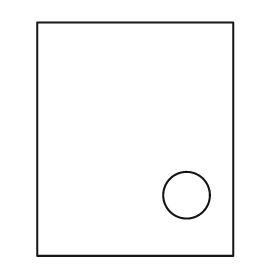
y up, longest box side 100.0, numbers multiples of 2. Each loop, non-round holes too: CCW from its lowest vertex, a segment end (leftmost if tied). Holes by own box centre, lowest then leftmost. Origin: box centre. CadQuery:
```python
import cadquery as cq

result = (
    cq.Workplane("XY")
    .moveTo(-42.0, -50.0)
    .lineTo(42.0, -50.0)
    .lineTo(42.0, 50.0)
    .lineTo(-42.0, 50.0)
    .close()
    .moveTo(22.0, -24.0)
    .circle(10.0)
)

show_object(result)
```